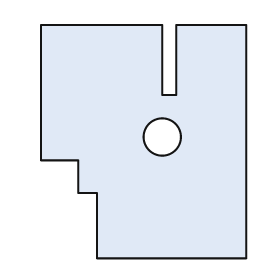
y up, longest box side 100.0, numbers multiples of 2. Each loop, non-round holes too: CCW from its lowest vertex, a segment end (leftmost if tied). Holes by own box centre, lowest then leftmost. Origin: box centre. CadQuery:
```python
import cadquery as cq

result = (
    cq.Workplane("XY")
    .moveTo(-20.0, -50.0)
    .lineTo(44.0, -50.0)
    .lineTo(44.0, 50.0)
    .lineTo(14.0, 50.0)
    .lineTo(14.0, 20.0)
    .lineTo(8.0, 20.0)
    .lineTo(8.0, 50.0)
    .lineTo(-44.0, 50.0)
    .lineTo(-44.0, -8.0)
    .lineTo(-28.0, -8.0)
    .lineTo(-28.0, -22.0)
    .lineTo(-20.0, -22.0)
    .close()
    .moveTo(8.0, 2.0)
    .circle(8.0)
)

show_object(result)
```